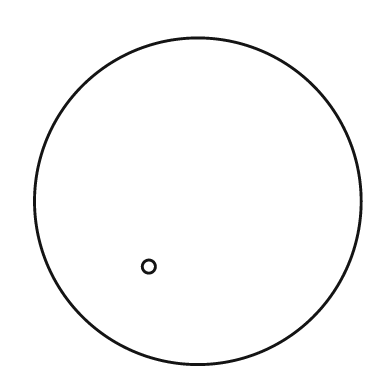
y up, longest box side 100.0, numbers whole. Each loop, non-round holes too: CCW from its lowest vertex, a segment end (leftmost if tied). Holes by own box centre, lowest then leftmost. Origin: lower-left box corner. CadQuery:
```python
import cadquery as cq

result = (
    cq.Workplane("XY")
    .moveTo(50.0, 50.0)
    .circle(50.0)
    .moveTo(35.0, 30.0)
    .circle(2.0)
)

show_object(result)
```